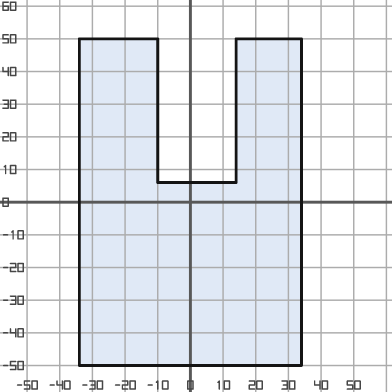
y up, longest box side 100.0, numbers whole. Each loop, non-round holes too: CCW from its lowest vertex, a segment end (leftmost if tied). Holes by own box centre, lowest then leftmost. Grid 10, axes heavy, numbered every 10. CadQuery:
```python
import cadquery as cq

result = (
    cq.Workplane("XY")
    .moveTo(-34.0, -50.0)
    .lineTo(34.0, -50.0)
    .lineTo(34.0, 50.0)
    .lineTo(14.0, 50.0)
    .lineTo(14.0, 6.0)
    .lineTo(-10.0, 6.0)
    .lineTo(-10.0, 50.0)
    .lineTo(-34.0, 50.0)
    .close()
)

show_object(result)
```